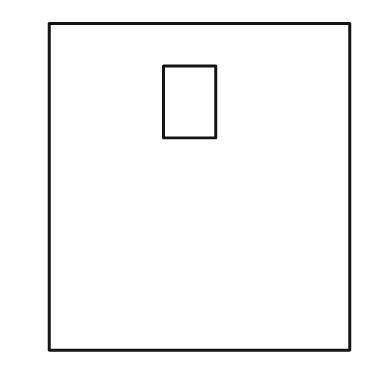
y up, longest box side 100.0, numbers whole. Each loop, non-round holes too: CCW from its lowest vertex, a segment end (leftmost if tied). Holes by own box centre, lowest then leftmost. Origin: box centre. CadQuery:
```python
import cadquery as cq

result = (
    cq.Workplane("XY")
    .moveTo(-46.0, -50.0)
    .lineTo(46.0, -50.0)
    .lineTo(46.0, 50.0)
    .lineTo(-46.0, 50.0)
    .close()
    .moveTo(-11.0, 15.0)
    .lineTo(5.0, 15.0)
    .lineTo(5.0, 37.0)
    .lineTo(-11.0, 37.0)
    .close()
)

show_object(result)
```